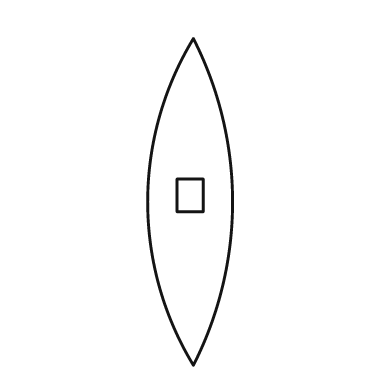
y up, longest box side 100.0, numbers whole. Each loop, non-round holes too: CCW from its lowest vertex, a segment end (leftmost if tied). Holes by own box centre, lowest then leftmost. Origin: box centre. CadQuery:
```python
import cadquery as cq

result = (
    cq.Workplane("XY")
    .moveTo(1.0, -50.0)
    .threePointArc((13.0, 0.0), (1.0, 50.0))
    .threePointArc((-13.0, 0.0), (1.0, -50.0))
    .close()
    .moveTo(-4.0, -3.0)
    .lineTo(4.0, -3.0)
    .lineTo(4.0, 7.0)
    .lineTo(-4.0, 7.0)
    .close()
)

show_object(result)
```